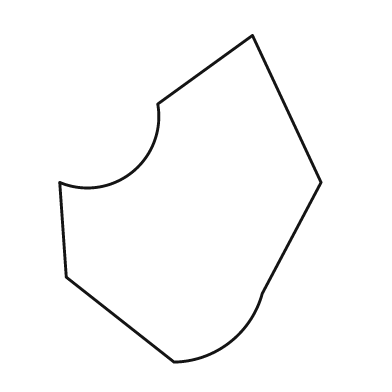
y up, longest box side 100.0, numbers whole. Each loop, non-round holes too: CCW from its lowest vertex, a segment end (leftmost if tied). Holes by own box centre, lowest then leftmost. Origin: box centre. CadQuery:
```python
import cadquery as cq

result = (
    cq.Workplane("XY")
    .moveTo(-5.0, -50.0)
    .threePointArc((12.0, -44.0), (22.0, -29.0))
    .lineTo(40.0, 5.0)
    .lineTo(19.0, 50.0)
    .lineTo(-10.0, 29.0)
    .threePointArc((-18.0, 8.0), (-40.0, 5.0))
    .lineTo(-38.0, -24.0)
    .close()
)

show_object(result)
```